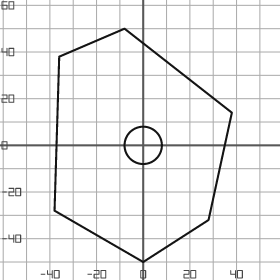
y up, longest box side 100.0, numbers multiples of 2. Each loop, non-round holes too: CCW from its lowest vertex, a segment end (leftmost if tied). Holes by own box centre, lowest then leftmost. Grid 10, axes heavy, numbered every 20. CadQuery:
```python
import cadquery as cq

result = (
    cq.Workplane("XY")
    .moveTo(0.0, -50.0)
    .lineTo(28.0, -32.0)
    .lineTo(38.0, 14.0)
    .lineTo(-8.0, 50.0)
    .lineTo(-36.0, 38.0)
    .lineTo(-38.0, -28.0)
    .close()
    .moveTo(0.0, 0.0)
    .circle(8.0)
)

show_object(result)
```